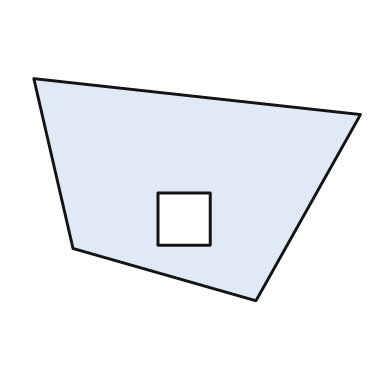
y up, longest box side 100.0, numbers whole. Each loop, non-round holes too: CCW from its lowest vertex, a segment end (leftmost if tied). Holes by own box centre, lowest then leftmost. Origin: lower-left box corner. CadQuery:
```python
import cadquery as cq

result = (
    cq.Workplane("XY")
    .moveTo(68.0, 0.0)
    .lineTo(100.0, 57.0)
    .lineTo(0.0, 68.0)
    .lineTo(12.0, 16.0)
    .close()
    .moveTo(38.0, 17.0)
    .lineTo(54.0, 17.0)
    .lineTo(54.0, 33.0)
    .lineTo(38.0, 33.0)
    .close()
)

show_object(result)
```